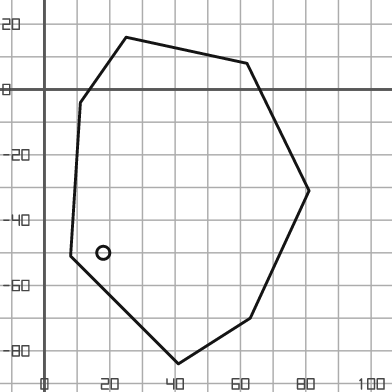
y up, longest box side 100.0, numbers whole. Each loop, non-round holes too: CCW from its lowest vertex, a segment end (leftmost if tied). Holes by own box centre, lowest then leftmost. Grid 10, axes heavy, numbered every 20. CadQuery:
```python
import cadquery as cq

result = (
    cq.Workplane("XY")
    .moveTo(41.0, -84.0)
    .lineTo(63.0, -70.0)
    .lineTo(81.0, -31.0)
    .lineTo(62.0, 8.0)
    .lineTo(25.0, 16.0)
    .lineTo(11.0, -4.0)
    .lineTo(8.0, -51.0)
    .close()
    .moveTo(18.0, -50.0)
    .circle(2.0)
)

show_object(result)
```